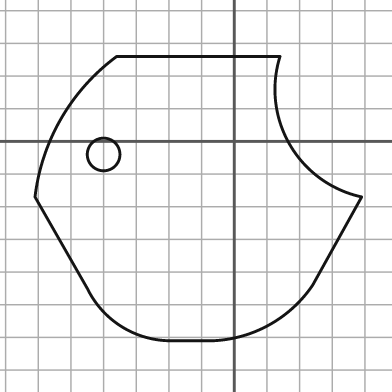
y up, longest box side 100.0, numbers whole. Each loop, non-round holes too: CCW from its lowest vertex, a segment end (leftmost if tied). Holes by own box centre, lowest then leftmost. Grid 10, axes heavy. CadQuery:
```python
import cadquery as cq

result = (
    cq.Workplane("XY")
    .moveTo(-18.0, -61.0)
    .lineTo(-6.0, -61.0)
    .threePointArc((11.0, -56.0), (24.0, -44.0))
    .lineTo(39.0, -17.0)
    .threePointArc((17.0, -1.0), (14.0, 26.0))
    .lineTo(-36.0, 26.0)
    .threePointArc((-53.0, 7.0), (-61.0, -17.0))
    .lineTo(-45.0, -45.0)
    .threePointArc((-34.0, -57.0), (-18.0, -61.0))
    .close()
    .moveTo(-40.0, -4.0)
    .circle(5.0)
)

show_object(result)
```